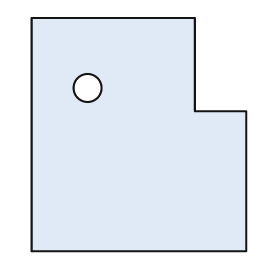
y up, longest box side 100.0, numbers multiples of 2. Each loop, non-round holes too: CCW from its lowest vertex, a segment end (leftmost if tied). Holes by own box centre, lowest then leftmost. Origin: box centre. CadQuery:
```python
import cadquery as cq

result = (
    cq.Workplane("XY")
    .moveTo(-46.0, -50.0)
    .lineTo(46.0, -50.0)
    .lineTo(46.0, 10.0)
    .lineTo(24.0, 10.0)
    .lineTo(24.0, 50.0)
    .lineTo(-46.0, 50.0)
    .close()
    .moveTo(-22.0, 20.0)
    .circle(6.0)
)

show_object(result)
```